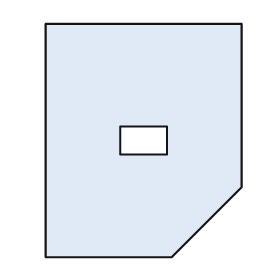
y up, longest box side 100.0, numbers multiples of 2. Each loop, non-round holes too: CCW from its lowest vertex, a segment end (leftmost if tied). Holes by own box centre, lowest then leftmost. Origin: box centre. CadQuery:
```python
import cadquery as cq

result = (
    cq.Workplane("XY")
    .moveTo(-42.0, -50.0)
    .lineTo(12.0, -50.0)
    .lineTo(42.0, -20.0)
    .lineTo(42.0, 50.0)
    .lineTo(-42.0, 50.0)
    .close()
    .moveTo(-10.0, -6.0)
    .lineTo(10.0, -6.0)
    .lineTo(10.0, 6.0)
    .lineTo(-10.0, 6.0)
    .close()
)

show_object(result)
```